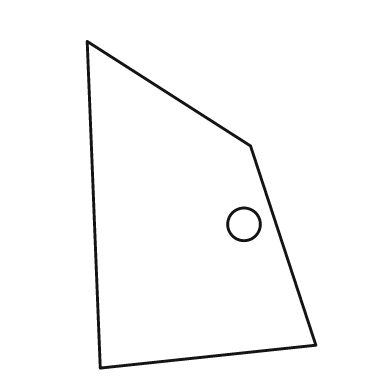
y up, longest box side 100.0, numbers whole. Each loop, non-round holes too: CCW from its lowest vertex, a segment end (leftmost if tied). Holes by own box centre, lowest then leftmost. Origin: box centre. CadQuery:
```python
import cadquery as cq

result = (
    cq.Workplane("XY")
    .moveTo(-31.0, -50.0)
    .lineTo(35.0, -43.0)
    .lineTo(15.0, 18.0)
    .lineTo(-35.0, 50.0)
    .close()
    .moveTo(13.0, -6.0)
    .circle(5.0)
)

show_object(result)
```